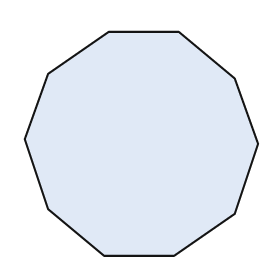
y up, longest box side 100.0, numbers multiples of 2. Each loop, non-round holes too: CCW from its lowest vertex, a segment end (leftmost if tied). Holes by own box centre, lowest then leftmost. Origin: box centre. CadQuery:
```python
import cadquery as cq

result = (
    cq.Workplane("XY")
    .moveTo(-16.0, -48.0)
    .lineTo(14.0, -48.0)
    .lineTo(40.0, -30.0)
    .lineTo(50.0, 0.0)
    .lineTo(40.0, 28.0)
    .lineTo(16.0, 48.0)
    .lineTo(-14.0, 48.0)
    .lineTo(-40.0, 30.0)
    .lineTo(-50.0, 2.0)
    .lineTo(-40.0, -28.0)
    .close()
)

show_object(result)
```